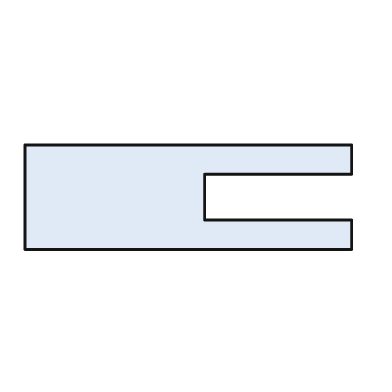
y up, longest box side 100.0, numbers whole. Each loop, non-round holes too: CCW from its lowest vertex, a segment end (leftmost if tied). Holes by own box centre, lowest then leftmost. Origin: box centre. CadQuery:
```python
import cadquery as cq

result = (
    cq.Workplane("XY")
    .moveTo(-50.0, -16.0)
    .lineTo(50.0, -16.0)
    .lineTo(50.0, -7.0)
    .lineTo(5.0, -7.0)
    .lineTo(5.0, 7.0)
    .lineTo(50.0, 7.0)
    .lineTo(50.0, 16.0)
    .lineTo(-50.0, 16.0)
    .close()
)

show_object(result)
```